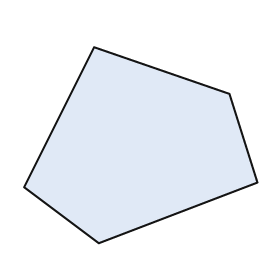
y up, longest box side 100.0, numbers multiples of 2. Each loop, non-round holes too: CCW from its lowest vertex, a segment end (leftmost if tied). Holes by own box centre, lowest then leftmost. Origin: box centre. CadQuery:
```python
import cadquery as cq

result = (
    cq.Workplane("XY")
    .moveTo(-18.0, -42.0)
    .lineTo(50.0, -16.0)
    .lineTo(38.0, 22.0)
    .lineTo(-20.0, 42.0)
    .lineTo(-50.0, -18.0)
    .close()
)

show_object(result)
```